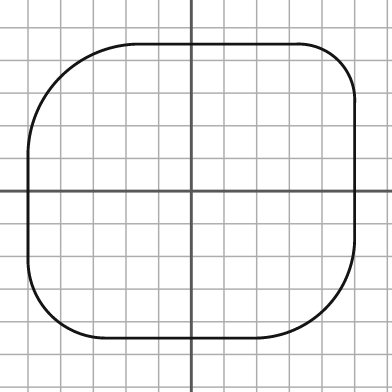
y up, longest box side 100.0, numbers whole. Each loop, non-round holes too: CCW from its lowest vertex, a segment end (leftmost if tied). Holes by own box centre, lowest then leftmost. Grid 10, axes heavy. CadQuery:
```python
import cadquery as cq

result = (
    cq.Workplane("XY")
    .moveTo(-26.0, -45.0)
    .lineTo(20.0, -45.0)
    .threePointArc((41.0, -36.0), (50.0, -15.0))
    .lineTo(50.0, 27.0)
    .threePointArc((45.0, 40.0), (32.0, 45.0))
    .lineTo(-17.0, 45.0)
    .threePointArc((-40.0, 35.0), (-50.0, 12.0))
    .lineTo(-50.0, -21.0)
    .threePointArc((-43.0, -38.0), (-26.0, -45.0))
    .close()
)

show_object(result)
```